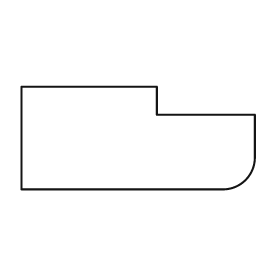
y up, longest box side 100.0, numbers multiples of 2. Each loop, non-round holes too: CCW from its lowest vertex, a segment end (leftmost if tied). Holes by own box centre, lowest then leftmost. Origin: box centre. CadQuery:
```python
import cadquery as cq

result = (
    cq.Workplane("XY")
    .moveTo(-50.0, -22.0)
    .lineTo(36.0, -22.0)
    .threePointArc((46.0, -18.0), (50.0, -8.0))
    .lineTo(50.0, 10.0)
    .lineTo(8.0, 10.0)
    .lineTo(8.0, 22.0)
    .lineTo(-50.0, 22.0)
    .close()
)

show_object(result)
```